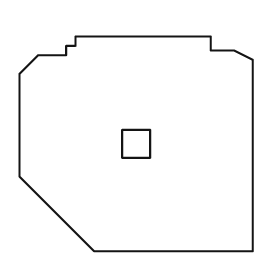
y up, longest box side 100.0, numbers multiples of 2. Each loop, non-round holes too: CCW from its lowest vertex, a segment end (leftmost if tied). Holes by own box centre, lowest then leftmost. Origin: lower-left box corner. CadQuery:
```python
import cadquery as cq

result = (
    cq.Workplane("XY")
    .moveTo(32.0, 0.0)
    .lineTo(100.0, 0.0)
    .lineTo(100.0, 82.0)
    .lineTo(92.0, 86.0)
    .lineTo(82.0, 86.0)
    .lineTo(82.0, 92.0)
    .lineTo(24.0, 92.0)
    .lineTo(24.0, 88.0)
    .lineTo(20.0, 88.0)
    .lineTo(20.0, 84.0)
    .lineTo(8.0, 84.0)
    .lineTo(0.0, 76.0)
    .lineTo(0.0, 32.0)
    .close()
    .moveTo(44.0, 40.0)
    .lineTo(56.0, 40.0)
    .lineTo(56.0, 52.0)
    .lineTo(44.0, 52.0)
    .close()
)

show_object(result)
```